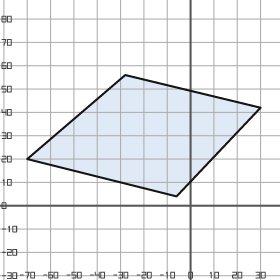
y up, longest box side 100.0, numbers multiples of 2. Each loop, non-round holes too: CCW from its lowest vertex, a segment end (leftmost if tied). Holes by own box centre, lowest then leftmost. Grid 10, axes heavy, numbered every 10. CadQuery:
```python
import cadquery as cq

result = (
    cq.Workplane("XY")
    .moveTo(-6.0, 4.0)
    .lineTo(30.0, 42.0)
    .lineTo(-28.0, 56.0)
    .lineTo(-70.0, 20.0)
    .close()
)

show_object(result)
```